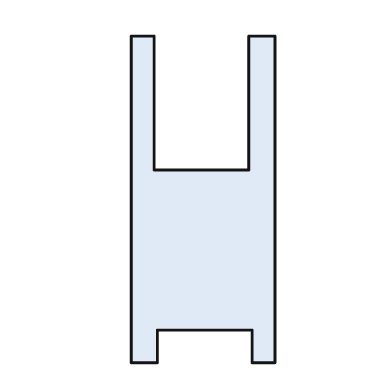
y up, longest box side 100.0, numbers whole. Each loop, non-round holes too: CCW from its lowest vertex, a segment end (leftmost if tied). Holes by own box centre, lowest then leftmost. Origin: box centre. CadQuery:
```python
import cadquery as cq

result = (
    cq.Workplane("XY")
    .moveTo(-22.0, -50.0)
    .lineTo(-14.0, -50.0)
    .lineTo(-14.0, -40.0)
    .lineTo(15.0, -40.0)
    .lineTo(15.0, -50.0)
    .lineTo(22.0, -50.0)
    .lineTo(22.0, 50.0)
    .lineTo(14.0, 50.0)
    .lineTo(14.0, 9.0)
    .lineTo(-15.0, 9.0)
    .lineTo(-15.0, 50.0)
    .lineTo(-22.0, 50.0)
    .close()
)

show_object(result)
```